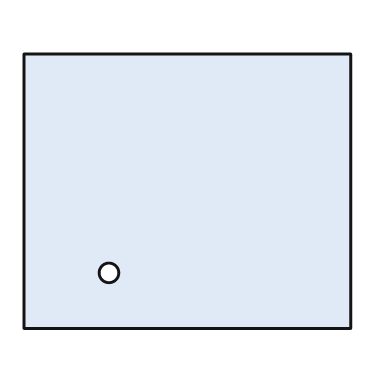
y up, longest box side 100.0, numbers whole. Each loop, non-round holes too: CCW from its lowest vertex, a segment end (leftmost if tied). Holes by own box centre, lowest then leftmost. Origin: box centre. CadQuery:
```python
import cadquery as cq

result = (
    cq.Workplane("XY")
    .moveTo(-50.0, -42.0)
    .lineTo(50.0, -42.0)
    .lineTo(50.0, 42.0)
    .lineTo(-50.0, 42.0)
    .close()
    .moveTo(-24.0, -25.0)
    .circle(3.0)
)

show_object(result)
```